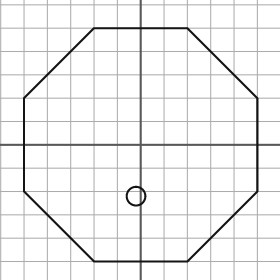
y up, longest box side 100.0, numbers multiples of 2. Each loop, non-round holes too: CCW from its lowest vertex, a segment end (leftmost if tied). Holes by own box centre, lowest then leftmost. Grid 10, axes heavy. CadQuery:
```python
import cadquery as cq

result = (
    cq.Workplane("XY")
    .moveTo(-20.0, -50.0)
    .lineTo(20.0, -50.0)
    .lineTo(50.0, -20.0)
    .lineTo(50.0, 20.0)
    .lineTo(20.0, 50.0)
    .lineTo(-20.0, 50.0)
    .lineTo(-50.0, 20.0)
    .lineTo(-50.0, -20.0)
    .close()
    .moveTo(-2.0, -22.0)
    .circle(4.0)
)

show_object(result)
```